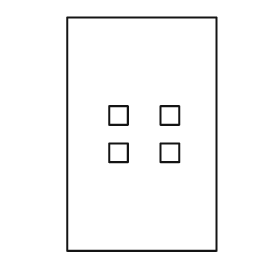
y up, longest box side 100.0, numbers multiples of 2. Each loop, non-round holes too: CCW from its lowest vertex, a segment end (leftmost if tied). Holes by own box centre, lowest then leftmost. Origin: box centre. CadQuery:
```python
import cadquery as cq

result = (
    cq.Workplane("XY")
    .moveTo(-32.0, -50.0)
    .lineTo(32.0, -50.0)
    .lineTo(32.0, 50.0)
    .lineTo(-32.0, 50.0)
    .close()
    .moveTo(-14.0, -12.0)
    .lineTo(-6.0, -12.0)
    .lineTo(-6.0, -4.0)
    .lineTo(-14.0, -4.0)
    .close()
    .moveTo(8.0, -12.0)
    .lineTo(16.0, -12.0)
    .lineTo(16.0, -4.0)
    .lineTo(8.0, -4.0)
    .close()
    .moveTo(-14.0, 4.0)
    .lineTo(-6.0, 4.0)
    .lineTo(-6.0, 12.0)
    .lineTo(-14.0, 12.0)
    .close()
    .moveTo(8.0, 4.0)
    .lineTo(16.0, 4.0)
    .lineTo(16.0, 12.0)
    .lineTo(8.0, 12.0)
    .close()
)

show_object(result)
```